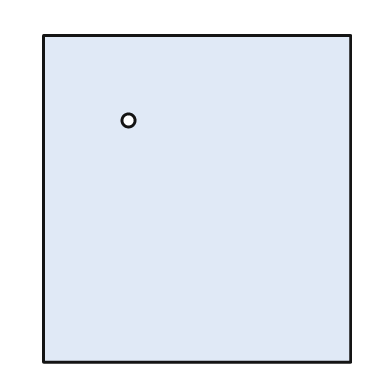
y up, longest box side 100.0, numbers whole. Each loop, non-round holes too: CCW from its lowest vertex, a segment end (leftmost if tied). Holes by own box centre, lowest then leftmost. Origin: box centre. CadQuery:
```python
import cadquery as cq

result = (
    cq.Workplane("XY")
    .moveTo(-47.0, -50.0)
    .lineTo(47.0, -50.0)
    .lineTo(47.0, 50.0)
    .lineTo(-47.0, 50.0)
    .close()
    .moveTo(-21.0, 24.0)
    .circle(2.0)
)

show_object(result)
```